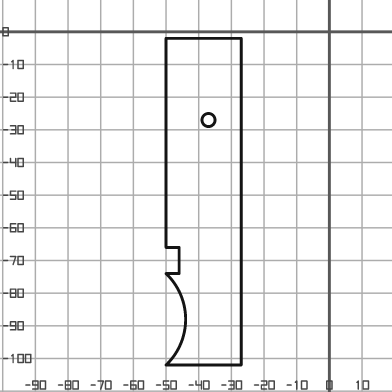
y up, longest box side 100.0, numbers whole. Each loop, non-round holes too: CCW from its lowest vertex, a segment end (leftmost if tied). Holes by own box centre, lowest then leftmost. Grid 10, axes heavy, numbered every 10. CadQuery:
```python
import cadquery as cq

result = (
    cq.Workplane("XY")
    .moveTo(-50.0, -102.0)
    .lineTo(-27.0, -102.0)
    .lineTo(-27.0, -2.0)
    .lineTo(-50.0, -2.0)
    .lineTo(-50.0, -66.0)
    .lineTo(-46.0, -66.0)
    .lineTo(-46.0, -74.0)
    .lineTo(-50.0, -74.0)
    .threePointArc((-44.0, -88.0), (-50.0, -102.0))
    .close()
    .moveTo(-37.0, -27.0)
    .circle(2.0)
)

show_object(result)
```